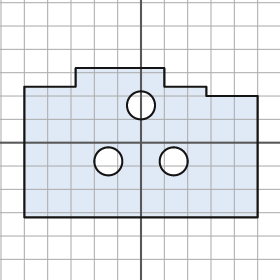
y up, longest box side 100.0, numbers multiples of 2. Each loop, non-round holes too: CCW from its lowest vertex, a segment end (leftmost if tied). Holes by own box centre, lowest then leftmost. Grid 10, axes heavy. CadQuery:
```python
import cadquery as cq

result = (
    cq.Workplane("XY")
    .moveTo(-50.0, -32.0)
    .lineTo(50.0, -32.0)
    .lineTo(50.0, 20.0)
    .lineTo(28.0, 20.0)
    .lineTo(28.0, 24.0)
    .lineTo(10.0, 24.0)
    .lineTo(10.0, 32.0)
    .lineTo(-28.0, 32.0)
    .lineTo(-28.0, 24.0)
    .lineTo(-50.0, 24.0)
    .close()
    .moveTo(-14.0, -8.0)
    .circle(6.0)
    .moveTo(14.0, -8.0)
    .circle(6.0)
    .moveTo(0.0, 16.0)
    .circle(6.0)
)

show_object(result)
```